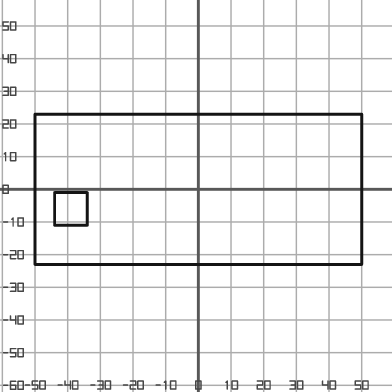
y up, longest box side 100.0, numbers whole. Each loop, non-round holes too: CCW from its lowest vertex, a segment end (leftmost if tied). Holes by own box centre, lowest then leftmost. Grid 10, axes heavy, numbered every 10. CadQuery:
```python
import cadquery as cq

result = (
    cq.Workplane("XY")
    .moveTo(-50.0, -23.0)
    .lineTo(50.0, -23.0)
    .lineTo(50.0, 23.0)
    .lineTo(-50.0, 23.0)
    .close()
    .moveTo(-44.0, -11.0)
    .lineTo(-34.0, -11.0)
    .lineTo(-34.0, -1.0)
    .lineTo(-44.0, -1.0)
    .close()
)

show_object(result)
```